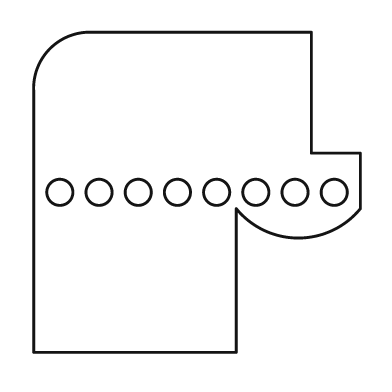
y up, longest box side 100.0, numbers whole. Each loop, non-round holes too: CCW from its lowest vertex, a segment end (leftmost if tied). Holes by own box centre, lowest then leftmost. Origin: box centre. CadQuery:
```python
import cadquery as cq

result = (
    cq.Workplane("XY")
    .moveTo(-50.0, -49.0)
    .lineTo(12.0, -49.0)
    .lineTo(12.0, -5.0)
    .threePointArc((31.0, -14.0), (50.0, -5.0))
    .lineTo(50.0, 12.0)
    .lineTo(35.0, 12.0)
    .lineTo(35.0, 49.0)
    .lineTo(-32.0, 49.0)
    .threePointArc((-45.0, 44.0), (-50.0, 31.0))
    .close()
    .moveTo(-42.0, 0.0)
    .circle(4.0)
    .moveTo(-30.0, 0.0)
    .circle(4.0)
    .moveTo(-18.0, 0.0)
    .circle(4.0)
    .moveTo(-6.0, 0.0)
    .circle(4.0)
    .moveTo(6.0, 0.0)
    .circle(4.0)
    .moveTo(18.0, 0.0)
    .circle(4.0)
    .moveTo(30.0, 0.0)
    .circle(4.0)
    .moveTo(42.0, 0.0)
    .circle(4.0)
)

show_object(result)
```